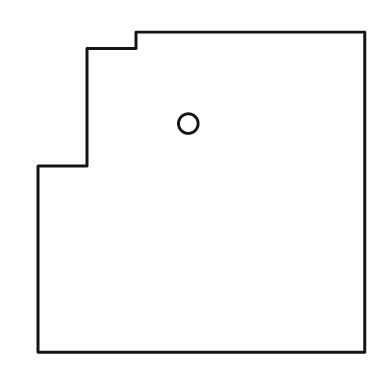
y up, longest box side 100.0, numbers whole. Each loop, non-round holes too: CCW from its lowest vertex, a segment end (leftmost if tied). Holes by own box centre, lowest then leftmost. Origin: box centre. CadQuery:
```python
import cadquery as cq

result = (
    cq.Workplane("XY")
    .moveTo(-50.0, -49.0)
    .lineTo(50.0, -49.0)
    .lineTo(50.0, 49.0)
    .lineTo(-20.0, 49.0)
    .lineTo(-20.0, 44.0)
    .lineTo(-35.0, 44.0)
    .lineTo(-35.0, 8.0)
    .lineTo(-50.0, 8.0)
    .close()
    .moveTo(-4.0, 21.0)
    .circle(3.0)
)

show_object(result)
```